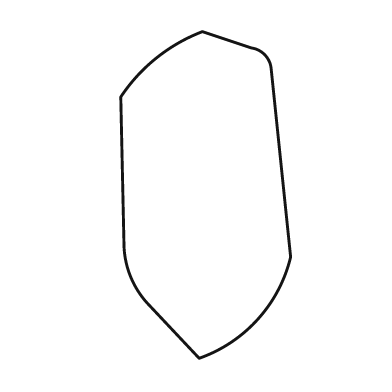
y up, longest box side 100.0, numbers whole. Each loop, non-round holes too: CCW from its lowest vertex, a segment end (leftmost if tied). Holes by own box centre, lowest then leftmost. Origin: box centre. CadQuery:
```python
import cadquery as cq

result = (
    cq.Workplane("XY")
    .moveTo(-2.0, -50.0)
    .threePointArc((16.0, -38.0), (26.0, -19.0))
    .lineTo(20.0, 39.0)
    .threePointArc((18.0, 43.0), (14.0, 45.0))
    .lineTo(-1.0, 50.0)
    .threePointArc((-15.0, 42.0), (-26.0, 30.0))
    .lineTo(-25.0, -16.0)
    .threePointArc((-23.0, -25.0), (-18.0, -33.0))
    .close()
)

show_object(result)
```